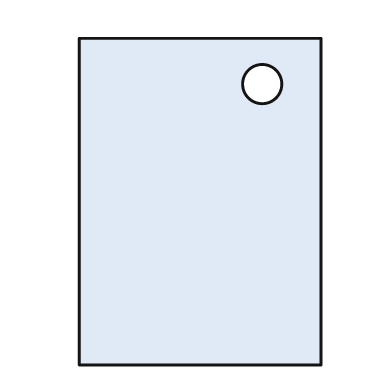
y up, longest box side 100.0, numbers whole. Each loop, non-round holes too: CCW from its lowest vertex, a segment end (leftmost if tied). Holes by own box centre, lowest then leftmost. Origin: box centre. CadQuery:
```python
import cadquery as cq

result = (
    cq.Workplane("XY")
    .moveTo(-37.0, -50.0)
    .lineTo(37.0, -50.0)
    .lineTo(37.0, 50.0)
    .lineTo(-37.0, 50.0)
    .close()
    .moveTo(19.0, 36.0)
    .circle(6.0)
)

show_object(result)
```